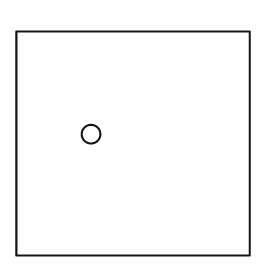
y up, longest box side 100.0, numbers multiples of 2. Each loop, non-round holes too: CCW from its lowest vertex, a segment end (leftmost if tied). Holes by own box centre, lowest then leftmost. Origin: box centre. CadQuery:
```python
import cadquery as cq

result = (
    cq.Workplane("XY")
    .moveTo(-50.0, -48.0)
    .lineTo(50.0, -48.0)
    .lineTo(50.0, 48.0)
    .lineTo(-50.0, 48.0)
    .close()
    .moveTo(-18.0, 4.0)
    .circle(4.0)
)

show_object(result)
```